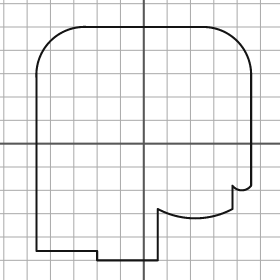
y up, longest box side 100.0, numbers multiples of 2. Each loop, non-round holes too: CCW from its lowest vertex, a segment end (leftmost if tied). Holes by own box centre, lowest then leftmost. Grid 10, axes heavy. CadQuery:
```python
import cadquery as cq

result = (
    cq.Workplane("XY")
    .moveTo(-20.0, -50.0)
    .lineTo(6.0, -50.0)
    .lineTo(6.0, -28.0)
    .threePointArc((22.0, -32.0), (38.0, -28.0))
    .lineTo(38.0, -18.0)
    .threePointArc((42.0, -20.0), (46.0, -18.0))
    .lineTo(46.0, 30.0)
    .threePointArc((40.0, 44.0), (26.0, 50.0))
    .lineTo(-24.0, 50.0)
    .threePointArc((-40.0, 44.0), (-46.0, 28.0))
    .lineTo(-46.0, -46.0)
    .lineTo(-20.0, -46.0)
    .close()
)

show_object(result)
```